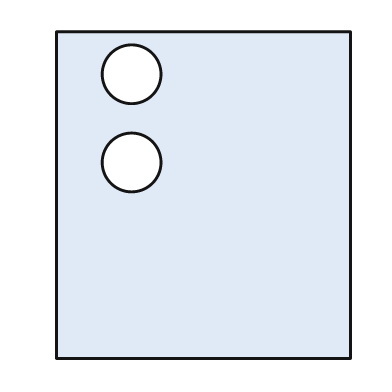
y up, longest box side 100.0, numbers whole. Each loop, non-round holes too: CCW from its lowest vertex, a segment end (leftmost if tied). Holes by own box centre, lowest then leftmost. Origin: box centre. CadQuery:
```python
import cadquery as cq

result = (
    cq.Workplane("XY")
    .moveTo(-45.0, -50.0)
    .lineTo(45.0, -50.0)
    .lineTo(45.0, 50.0)
    .lineTo(-45.0, 50.0)
    .close()
    .moveTo(-22.0, 10.0)
    .circle(9.0)
    .moveTo(-22.0, 37.0)
    .circle(9.0)
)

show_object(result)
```